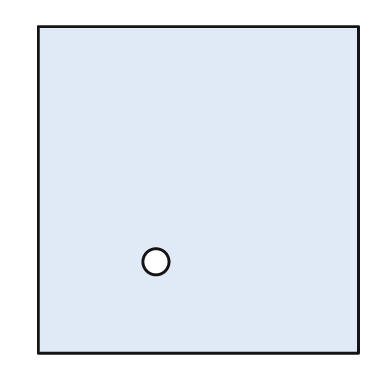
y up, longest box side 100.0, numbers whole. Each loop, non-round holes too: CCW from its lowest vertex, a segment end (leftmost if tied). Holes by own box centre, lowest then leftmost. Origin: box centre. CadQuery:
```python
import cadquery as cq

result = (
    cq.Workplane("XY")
    .moveTo(-49.0, -50.0)
    .lineTo(49.0, -50.0)
    .lineTo(49.0, 50.0)
    .lineTo(-49.0, 50.0)
    .close()
    .moveTo(-13.0, -22.0)
    .circle(4.0)
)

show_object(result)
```